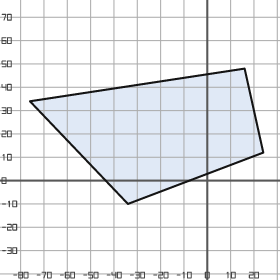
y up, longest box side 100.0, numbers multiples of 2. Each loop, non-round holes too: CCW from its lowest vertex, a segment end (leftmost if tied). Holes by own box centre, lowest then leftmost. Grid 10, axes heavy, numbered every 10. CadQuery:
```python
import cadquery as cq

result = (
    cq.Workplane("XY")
    .moveTo(-34.0, -10.0)
    .lineTo(24.0, 12.0)
    .lineTo(16.0, 48.0)
    .lineTo(-76.0, 34.0)
    .close()
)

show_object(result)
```